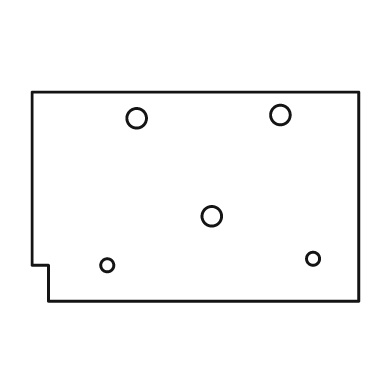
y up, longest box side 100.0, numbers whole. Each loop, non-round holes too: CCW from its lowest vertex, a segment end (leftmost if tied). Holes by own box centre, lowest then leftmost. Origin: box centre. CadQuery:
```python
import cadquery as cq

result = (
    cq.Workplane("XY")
    .moveTo(-45.0, -32.0)
    .lineTo(50.0, -32.0)
    .lineTo(50.0, 32.0)
    .lineTo(-50.0, 32.0)
    .lineTo(-50.0, -21.0)
    .lineTo(-45.0, -21.0)
    .close()
    .moveTo(-27.0, -21.0)
    .circle(2.0)
    .moveTo(36.0, -19.0)
    .circle(2.0)
    .moveTo(5.0, -6.0)
    .circle(3.0)
    .moveTo(-18.0, 24.0)
    .circle(3.0)
    .moveTo(26.0, 25.0)
    .circle(3.0)
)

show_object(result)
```